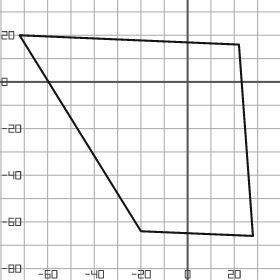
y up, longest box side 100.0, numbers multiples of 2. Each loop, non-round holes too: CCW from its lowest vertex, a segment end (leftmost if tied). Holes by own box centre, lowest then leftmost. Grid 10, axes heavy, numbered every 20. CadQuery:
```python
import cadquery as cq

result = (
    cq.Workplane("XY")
    .moveTo(28.0, -66.0)
    .lineTo(22.0, 16.0)
    .lineTo(-72.0, 20.0)
    .lineTo(-20.0, -64.0)
    .close()
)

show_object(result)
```